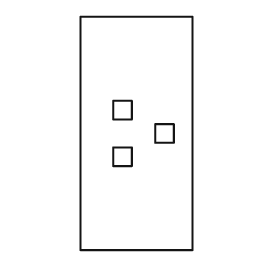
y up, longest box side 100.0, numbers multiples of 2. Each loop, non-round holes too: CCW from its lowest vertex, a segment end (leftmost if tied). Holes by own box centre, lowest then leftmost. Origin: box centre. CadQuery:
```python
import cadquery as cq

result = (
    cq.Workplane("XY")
    .moveTo(-24.0, -50.0)
    .lineTo(24.0, -50.0)
    .lineTo(24.0, 50.0)
    .lineTo(-24.0, 50.0)
    .close()
    .moveTo(-10.0, -14.0)
    .lineTo(-2.0, -14.0)
    .lineTo(-2.0, -6.0)
    .lineTo(-10.0, -6.0)
    .close()
    .moveTo(8.0, -4.0)
    .lineTo(16.0, -4.0)
    .lineTo(16.0, 4.0)
    .lineTo(8.0, 4.0)
    .close()
    .moveTo(-10.0, 6.0)
    .lineTo(-2.0, 6.0)
    .lineTo(-2.0, 14.0)
    .lineTo(-10.0, 14.0)
    .close()
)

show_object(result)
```